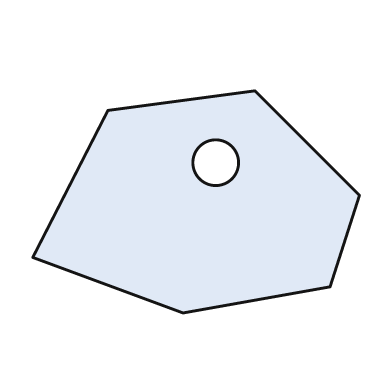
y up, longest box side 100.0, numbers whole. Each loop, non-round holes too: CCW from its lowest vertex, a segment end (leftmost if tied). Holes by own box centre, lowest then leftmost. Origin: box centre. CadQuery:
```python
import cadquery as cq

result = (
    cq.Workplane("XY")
    .moveTo(-4.0, -34.0)
    .lineTo(41.0, -26.0)
    .lineTo(50.0, 2.0)
    .lineTo(18.0, 34.0)
    .lineTo(-27.0, 28.0)
    .lineTo(-50.0, -17.0)
    .close()
    .moveTo(6.0, 12.0)
    .circle(7.0)
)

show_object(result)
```